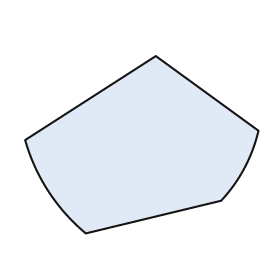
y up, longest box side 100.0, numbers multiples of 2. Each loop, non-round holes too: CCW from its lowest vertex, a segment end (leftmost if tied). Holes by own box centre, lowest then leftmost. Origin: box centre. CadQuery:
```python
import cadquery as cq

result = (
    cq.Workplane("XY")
    .moveTo(-24.0, -38.0)
    .lineTo(34.0, -24.0)
    .threePointArc((44.0, -10.0), (50.0, 6.0))
    .lineTo(6.0, 38.0)
    .lineTo(-50.0, 2.0)
    .threePointArc((-40.0, -20.0), (-24.0, -38.0))
    .close()
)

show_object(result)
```